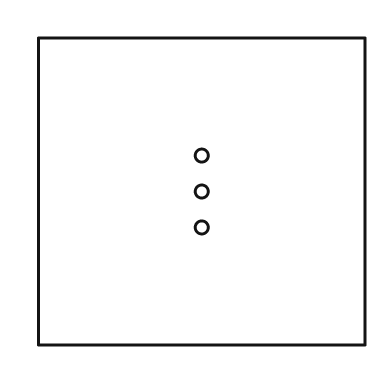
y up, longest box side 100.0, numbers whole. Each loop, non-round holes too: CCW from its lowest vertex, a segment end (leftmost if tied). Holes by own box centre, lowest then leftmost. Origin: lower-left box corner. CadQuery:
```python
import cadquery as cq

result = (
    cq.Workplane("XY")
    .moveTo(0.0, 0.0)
    .lineTo(100.0, 0.0)
    .lineTo(100.0, 94.0)
    .lineTo(0.0, 94.0)
    .close()
    .moveTo(50.0, 36.0)
    .circle(2.0)
    .moveTo(50.0, 47.0)
    .circle(2.0)
    .moveTo(50.0, 58.0)
    .circle(2.0)
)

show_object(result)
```